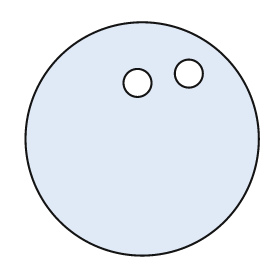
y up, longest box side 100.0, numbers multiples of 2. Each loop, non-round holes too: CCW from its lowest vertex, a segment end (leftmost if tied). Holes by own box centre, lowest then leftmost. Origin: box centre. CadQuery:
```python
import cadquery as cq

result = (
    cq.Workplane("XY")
    .moveTo(0.0, 0.0)
    .circle(50.0)
    .moveTo(-2.0, 24.0)
    .circle(6.0)
    .moveTo(20.0, 28.0)
    .circle(6.0)
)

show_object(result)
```